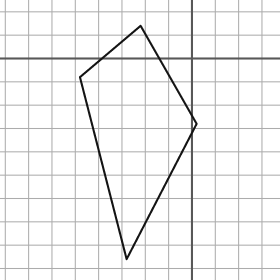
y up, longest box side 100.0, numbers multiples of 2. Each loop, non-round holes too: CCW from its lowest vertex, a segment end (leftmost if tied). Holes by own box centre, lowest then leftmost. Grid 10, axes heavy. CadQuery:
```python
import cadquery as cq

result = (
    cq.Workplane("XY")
    .moveTo(-28.0, -86.0)
    .lineTo(2.0, -28.0)
    .lineTo(-22.0, 14.0)
    .lineTo(-48.0, -8.0)
    .close()
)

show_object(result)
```